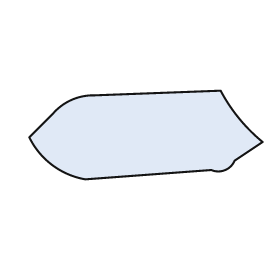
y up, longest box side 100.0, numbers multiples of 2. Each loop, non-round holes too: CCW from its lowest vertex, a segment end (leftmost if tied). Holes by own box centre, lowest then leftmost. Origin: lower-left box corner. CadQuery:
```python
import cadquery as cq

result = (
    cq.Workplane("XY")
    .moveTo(24.0, 0.0)
    .lineTo(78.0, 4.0)
    .threePointArc((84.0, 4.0), (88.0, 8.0))
    .lineTo(100.0, 16.0)
    .threePointArc((90.0, 26.0), (82.0, 38.0))
    .lineTo(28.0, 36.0)
    .threePointArc((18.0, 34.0), (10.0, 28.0))
    .lineTo(0.0, 18.0)
    .threePointArc((10.0, 6.0), (24.0, 0.0))
    .close()
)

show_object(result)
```